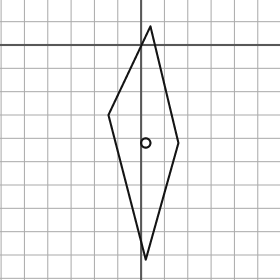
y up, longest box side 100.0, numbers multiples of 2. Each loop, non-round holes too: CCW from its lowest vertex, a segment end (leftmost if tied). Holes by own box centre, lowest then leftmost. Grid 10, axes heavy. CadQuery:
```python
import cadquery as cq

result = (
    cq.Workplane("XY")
    .moveTo(2.0, -92.0)
    .lineTo(16.0, -42.0)
    .lineTo(4.0, 8.0)
    .lineTo(-14.0, -30.0)
    .close()
    .moveTo(2.0, -42.0)
    .circle(2.0)
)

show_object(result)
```